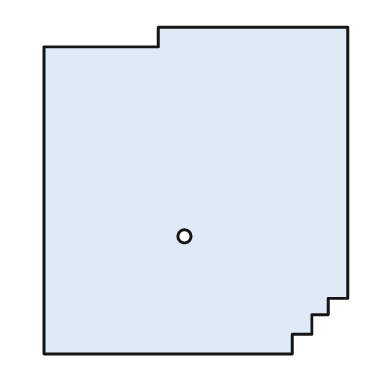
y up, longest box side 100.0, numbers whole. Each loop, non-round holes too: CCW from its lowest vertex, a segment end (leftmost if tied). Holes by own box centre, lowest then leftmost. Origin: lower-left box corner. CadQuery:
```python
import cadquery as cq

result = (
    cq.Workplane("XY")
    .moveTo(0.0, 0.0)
    .lineTo(76.0, 0.0)
    .lineTo(76.0, 6.0)
    .lineTo(82.0, 6.0)
    .lineTo(82.0, 12.0)
    .lineTo(87.0, 12.0)
    .lineTo(87.0, 17.0)
    .lineTo(93.0, 17.0)
    .lineTo(93.0, 100.0)
    .lineTo(35.0, 100.0)
    .lineTo(35.0, 94.0)
    .lineTo(0.0, 94.0)
    .close()
    .moveTo(43.0, 36.0)
    .circle(2.0)
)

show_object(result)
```